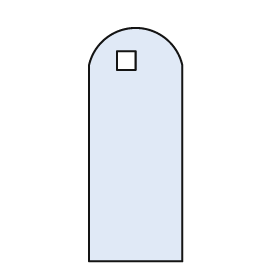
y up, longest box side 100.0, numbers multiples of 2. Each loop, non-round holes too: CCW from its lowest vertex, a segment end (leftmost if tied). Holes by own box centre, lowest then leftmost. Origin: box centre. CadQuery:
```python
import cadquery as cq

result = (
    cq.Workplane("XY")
    .moveTo(-20.0, -50.0)
    .lineTo(20.0, -50.0)
    .lineTo(20.0, 34.0)
    .threePointArc((0.0, 50.0), (-20.0, 34.0))
    .close()
    .moveTo(-8.0, 32.0)
    .lineTo(0.0, 32.0)
    .lineTo(0.0, 40.0)
    .lineTo(-8.0, 40.0)
    .close()
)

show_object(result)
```